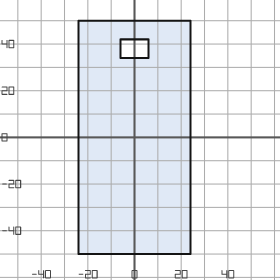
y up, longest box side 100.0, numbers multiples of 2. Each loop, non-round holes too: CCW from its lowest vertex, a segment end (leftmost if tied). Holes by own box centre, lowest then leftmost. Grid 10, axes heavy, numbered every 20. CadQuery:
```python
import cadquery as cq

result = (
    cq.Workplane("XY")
    .moveTo(-24.0, -50.0)
    .lineTo(24.0, -50.0)
    .lineTo(24.0, 50.0)
    .lineTo(-24.0, 50.0)
    .close()
    .moveTo(-6.0, 34.0)
    .lineTo(6.0, 34.0)
    .lineTo(6.0, 42.0)
    .lineTo(-6.0, 42.0)
    .close()
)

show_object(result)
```